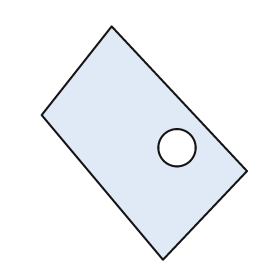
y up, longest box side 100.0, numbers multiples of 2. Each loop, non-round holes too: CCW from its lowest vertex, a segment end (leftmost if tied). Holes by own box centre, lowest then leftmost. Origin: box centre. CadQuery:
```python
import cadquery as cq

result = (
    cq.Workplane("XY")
    .moveTo(8.0, -50.0)
    .lineTo(44.0, -12.0)
    .lineTo(-14.0, 50.0)
    .lineTo(-44.0, 12.0)
    .close()
    .moveTo(14.0, -2.0)
    .circle(8.0)
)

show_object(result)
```